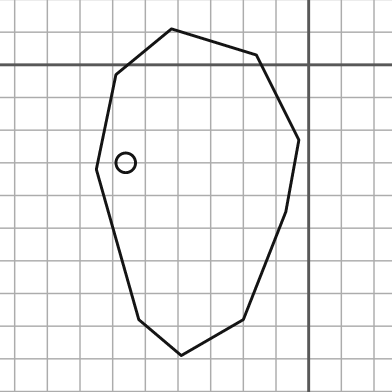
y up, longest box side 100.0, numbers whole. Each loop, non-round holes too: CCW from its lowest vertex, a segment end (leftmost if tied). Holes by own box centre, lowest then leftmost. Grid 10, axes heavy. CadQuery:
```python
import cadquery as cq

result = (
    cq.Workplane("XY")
    .moveTo(-39.0, -89.0)
    .lineTo(-20.0, -78.0)
    .lineTo(-7.0, -45.0)
    .lineTo(-3.0, -23.0)
    .lineTo(-16.0, 3.0)
    .lineTo(-42.0, 11.0)
    .lineTo(-59.0, -3.0)
    .lineTo(-65.0, -32.0)
    .lineTo(-52.0, -78.0)
    .close()
    .moveTo(-56.0, -30.0)
    .circle(3.0)
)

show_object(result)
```